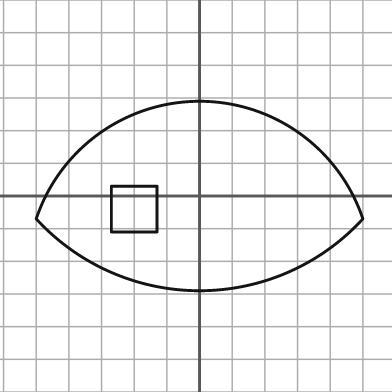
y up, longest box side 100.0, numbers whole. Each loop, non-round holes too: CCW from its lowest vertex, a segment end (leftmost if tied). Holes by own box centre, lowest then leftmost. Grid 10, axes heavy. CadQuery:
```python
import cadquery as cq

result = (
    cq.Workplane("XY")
    .moveTo(-50.0, -7.0)
    .threePointArc((0.0, -29.0), (50.0, -7.0))
    .threePointArc((0.0, 29.0), (-50.0, -7.0))
    .close()
    .moveTo(-27.0, -11.0)
    .lineTo(-13.0, -11.0)
    .lineTo(-13.0, 3.0)
    .lineTo(-27.0, 3.0)
    .close()
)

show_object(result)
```